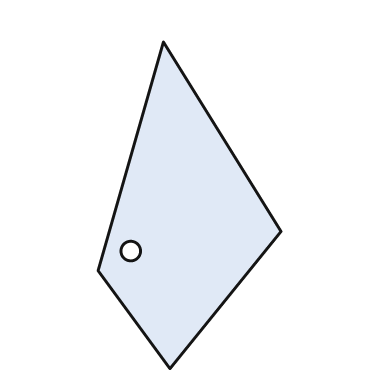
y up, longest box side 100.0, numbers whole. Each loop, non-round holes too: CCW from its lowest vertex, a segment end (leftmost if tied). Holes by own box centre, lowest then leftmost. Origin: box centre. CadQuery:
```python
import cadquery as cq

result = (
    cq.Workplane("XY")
    .moveTo(-6.0, -50.0)
    .lineTo(28.0, -8.0)
    .lineTo(-8.0, 50.0)
    .lineTo(-28.0, -20.0)
    .close()
    .moveTo(-18.0, -14.0)
    .circle(3.0)
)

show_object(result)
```